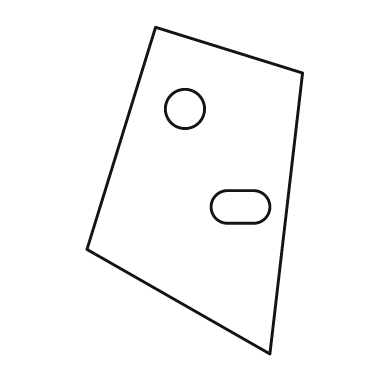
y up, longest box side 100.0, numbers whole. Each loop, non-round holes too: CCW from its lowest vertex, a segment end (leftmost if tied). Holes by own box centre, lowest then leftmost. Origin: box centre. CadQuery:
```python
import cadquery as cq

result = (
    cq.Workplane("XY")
    .moveTo(23.0, -50.0)
    .lineTo(33.0, 36.0)
    .lineTo(-12.0, 50.0)
    .lineTo(-33.0, -18.0)
    .close()
    .moveTo(10.0, -10.0)
    .lineTo(18.0, -10.0)
    .threePointArc((23.0, -5.0), (18.0, 0.0))
    .lineTo(10.0, 0.0)
    .threePointArc((5.0, -5.0), (10.0, -10.0))
    .close()
    .moveTo(-3.0, 25.0)
    .circle(6.0)
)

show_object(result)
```